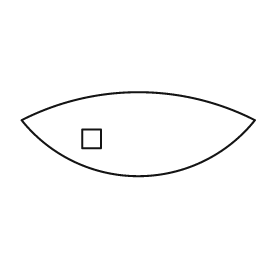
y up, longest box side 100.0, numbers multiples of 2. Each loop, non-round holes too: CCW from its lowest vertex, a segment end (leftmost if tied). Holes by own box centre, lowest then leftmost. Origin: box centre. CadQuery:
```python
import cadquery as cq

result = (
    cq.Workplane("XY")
    .moveTo(-50.0, 6.0)
    .threePointArc((0.0, -18.0), (50.0, 6.0))
    .threePointArc((0.0, 18.0), (-50.0, 6.0))
    .close()
    .moveTo(-24.0, -6.0)
    .lineTo(-16.0, -6.0)
    .lineTo(-16.0, 2.0)
    .lineTo(-24.0, 2.0)
    .close()
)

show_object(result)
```